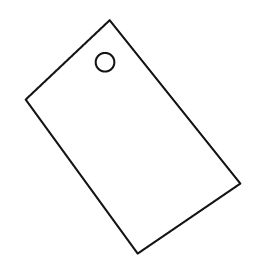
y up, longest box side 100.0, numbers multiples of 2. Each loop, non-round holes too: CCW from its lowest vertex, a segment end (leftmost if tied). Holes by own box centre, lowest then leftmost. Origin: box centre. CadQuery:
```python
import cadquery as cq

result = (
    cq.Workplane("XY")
    .moveTo(2.0, -50.0)
    .lineTo(46.0, -20.0)
    .lineTo(-10.0, 50.0)
    .lineTo(-46.0, 16.0)
    .close()
    .moveTo(-12.0, 32.0)
    .circle(4.0)
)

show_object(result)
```